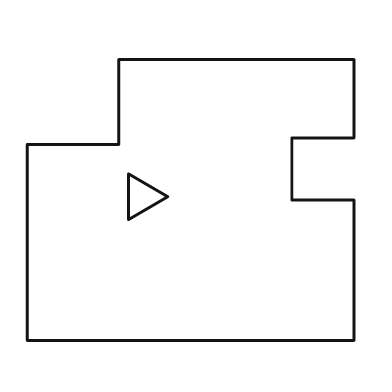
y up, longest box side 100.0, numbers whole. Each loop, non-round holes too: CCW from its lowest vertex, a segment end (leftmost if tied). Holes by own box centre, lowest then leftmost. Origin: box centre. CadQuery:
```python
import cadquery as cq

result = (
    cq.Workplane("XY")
    .moveTo(-50.0, -43.0)
    .lineTo(50.0, -43.0)
    .lineTo(50.0, 0.0)
    .lineTo(31.0, 0.0)
    .lineTo(31.0, 19.0)
    .lineTo(50.0, 19.0)
    .lineTo(50.0, 43.0)
    .lineTo(-22.0, 43.0)
    .lineTo(-22.0, 17.0)
    .lineTo(-50.0, 17.0)
    .close()
    .moveTo(-19.0, -6.0)
    .lineTo(-7.0, 1.0)
    .lineTo(-19.0, 8.0)
    .close()
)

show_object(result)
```